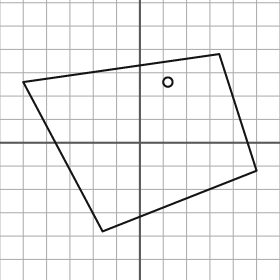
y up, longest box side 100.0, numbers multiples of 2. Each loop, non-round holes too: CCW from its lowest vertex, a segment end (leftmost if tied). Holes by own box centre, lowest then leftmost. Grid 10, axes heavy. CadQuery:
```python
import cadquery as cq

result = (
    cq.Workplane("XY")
    .moveTo(-16.0, -38.0)
    .lineTo(50.0, -12.0)
    .lineTo(34.0, 38.0)
    .lineTo(-50.0, 26.0)
    .close()
    .moveTo(12.0, 26.0)
    .circle(2.0)
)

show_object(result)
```